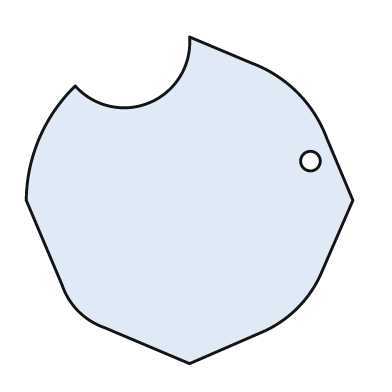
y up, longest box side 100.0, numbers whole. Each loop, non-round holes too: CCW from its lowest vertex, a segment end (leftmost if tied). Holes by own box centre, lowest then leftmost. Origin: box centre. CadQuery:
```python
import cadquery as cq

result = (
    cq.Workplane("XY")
    .moveTo(0.0, -50.0)
    .lineTo(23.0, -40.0)
    .threePointArc((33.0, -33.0), (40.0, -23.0))
    .lineTo(50.0, 0.0)
    .lineTo(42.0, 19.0)
    .threePointArc((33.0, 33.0), (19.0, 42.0))
    .lineTo(0.0, 50.0)
    .threePointArc((-12.0, 30.0), (-35.0, 35.0))
    .threePointArc((-46.0, 19.0), (-50.0, 0.0))
    .lineTo(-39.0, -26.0)
    .threePointArc((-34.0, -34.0), (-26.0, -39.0))
    .close()
    .moveTo(37.0, 12.0)
    .circle(3.0)
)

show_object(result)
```